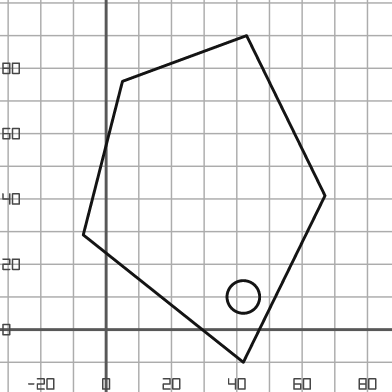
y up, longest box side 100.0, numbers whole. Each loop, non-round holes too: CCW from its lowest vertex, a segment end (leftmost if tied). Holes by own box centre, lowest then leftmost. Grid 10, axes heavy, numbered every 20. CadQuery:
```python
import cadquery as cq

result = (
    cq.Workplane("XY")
    .moveTo(42.0, -10.0)
    .lineTo(67.0, 41.0)
    .lineTo(43.0, 90.0)
    .lineTo(5.0, 76.0)
    .lineTo(-7.0, 29.0)
    .close()
    .moveTo(42.0, 10.0)
    .circle(5.0)
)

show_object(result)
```